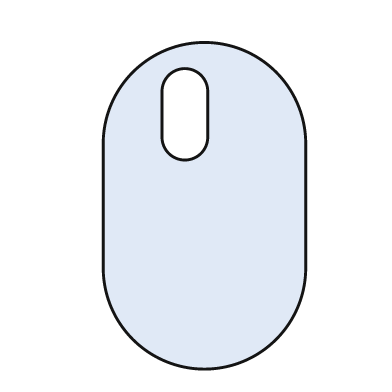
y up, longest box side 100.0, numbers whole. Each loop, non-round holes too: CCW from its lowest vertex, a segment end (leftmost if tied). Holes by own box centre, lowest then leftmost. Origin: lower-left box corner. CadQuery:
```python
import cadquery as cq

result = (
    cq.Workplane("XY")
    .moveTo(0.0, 31.0)
    .threePointArc((31.0, 0.0), (62.0, 31.0))
    .lineTo(62.0, 69.0)
    .threePointArc((31.0, 100.0), (0.0, 69.0))
    .close()
    .moveTo(18.0, 71.0)
    .threePointArc((25.0, 64.0), (32.0, 71.0))
    .lineTo(32.0, 85.0)
    .threePointArc((25.0, 92.0), (18.0, 85.0))
    .close()
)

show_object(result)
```